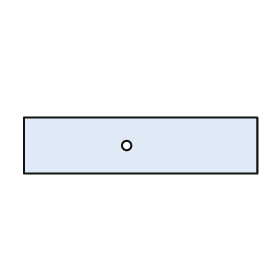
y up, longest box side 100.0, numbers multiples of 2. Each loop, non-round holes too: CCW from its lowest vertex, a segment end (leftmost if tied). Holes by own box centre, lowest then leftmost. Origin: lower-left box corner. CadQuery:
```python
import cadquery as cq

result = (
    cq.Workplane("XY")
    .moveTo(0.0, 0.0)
    .lineTo(100.0, 0.0)
    .lineTo(100.0, 24.0)
    .lineTo(0.0, 24.0)
    .close()
    .moveTo(44.0, 12.0)
    .circle(2.0)
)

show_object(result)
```